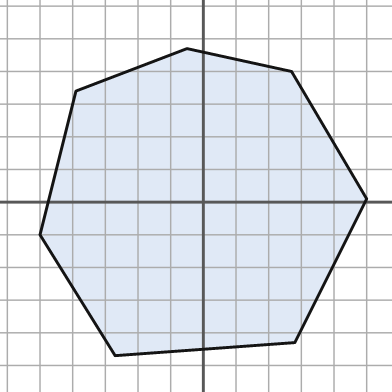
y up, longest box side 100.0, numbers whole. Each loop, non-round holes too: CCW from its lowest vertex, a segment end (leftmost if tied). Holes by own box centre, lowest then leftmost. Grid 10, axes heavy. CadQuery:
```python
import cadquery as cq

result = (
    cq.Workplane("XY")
    .moveTo(-27.0, -47.0)
    .lineTo(28.0, -43.0)
    .lineTo(50.0, 1.0)
    .lineTo(27.0, 40.0)
    .lineTo(-5.0, 47.0)
    .lineTo(-39.0, 34.0)
    .lineTo(-50.0, -10.0)
    .close()
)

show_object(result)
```